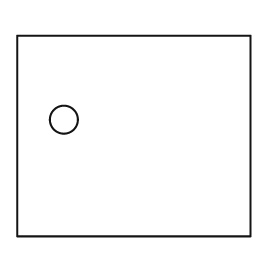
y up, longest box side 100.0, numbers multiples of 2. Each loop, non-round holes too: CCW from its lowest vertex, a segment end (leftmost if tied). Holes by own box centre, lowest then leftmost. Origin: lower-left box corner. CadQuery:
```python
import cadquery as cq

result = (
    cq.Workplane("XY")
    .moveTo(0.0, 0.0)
    .lineTo(100.0, 0.0)
    .lineTo(100.0, 86.0)
    .lineTo(0.0, 86.0)
    .close()
    .moveTo(20.0, 50.0)
    .circle(6.0)
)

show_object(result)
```